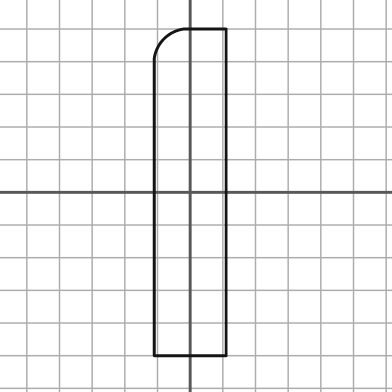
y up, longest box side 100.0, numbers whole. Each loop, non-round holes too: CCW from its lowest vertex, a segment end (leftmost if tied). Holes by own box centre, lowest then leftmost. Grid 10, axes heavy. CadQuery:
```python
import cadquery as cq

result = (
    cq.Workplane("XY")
    .moveTo(-11.0, -50.0)
    .lineTo(11.0, -50.0)
    .lineTo(11.0, 50.0)
    .lineTo(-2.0, 50.0)
    .threePointArc((-8.0, 47.0), (-11.0, 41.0))
    .close()
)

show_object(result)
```